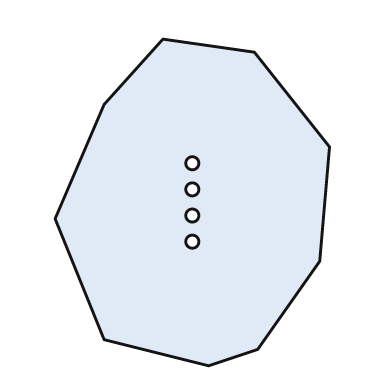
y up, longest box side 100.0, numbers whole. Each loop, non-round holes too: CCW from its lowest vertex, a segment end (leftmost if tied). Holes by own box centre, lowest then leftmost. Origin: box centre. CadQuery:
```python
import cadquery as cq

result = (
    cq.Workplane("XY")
    .moveTo(5.0, -50.0)
    .lineTo(20.0, -45.0)
    .lineTo(39.0, -18.0)
    .lineTo(42.0, 17.0)
    .lineTo(19.0, 46.0)
    .lineTo(-9.0, 50.0)
    .lineTo(-27.0, 30.0)
    .lineTo(-42.0, -5.0)
    .lineTo(-27.0, -42.0)
    .close()
    .moveTo(0.0, -12.0)
    .circle(2.0)
    .moveTo(0.0, -4.0)
    .circle(2.0)
    .moveTo(0.0, 4.0)
    .circle(2.0)
    .moveTo(0.0, 12.0)
    .circle(2.0)
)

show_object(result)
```